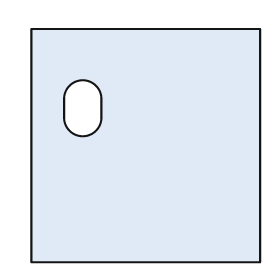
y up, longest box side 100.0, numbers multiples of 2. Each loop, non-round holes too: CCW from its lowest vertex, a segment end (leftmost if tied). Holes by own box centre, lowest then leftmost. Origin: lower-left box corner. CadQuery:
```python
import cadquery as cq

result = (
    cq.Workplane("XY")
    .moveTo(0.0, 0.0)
    .lineTo(98.0, 0.0)
    .lineTo(98.0, 100.0)
    .lineTo(0.0, 100.0)
    .close()
    .moveTo(14.0, 62.0)
    .threePointArc((22.0, 54.0), (30.0, 62.0))
    .lineTo(30.0, 70.0)
    .threePointArc((22.0, 78.0), (14.0, 70.0))
    .close()
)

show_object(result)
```